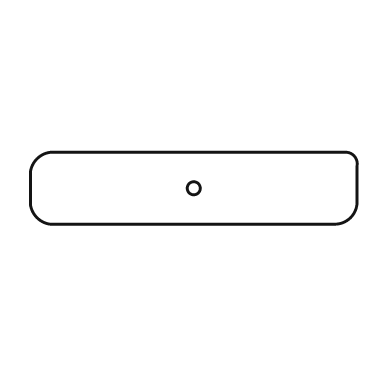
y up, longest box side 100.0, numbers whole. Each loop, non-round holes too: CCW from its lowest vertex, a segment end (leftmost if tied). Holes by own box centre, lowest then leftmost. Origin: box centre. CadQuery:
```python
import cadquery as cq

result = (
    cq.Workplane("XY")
    .moveTo(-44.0, -11.0)
    .lineTo(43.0, -11.0)
    .threePointArc((48.0, -9.0), (50.0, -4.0))
    .lineTo(50.0, 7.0)
    .threePointArc((49.0, 10.0), (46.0, 11.0))
    .lineTo(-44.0, 11.0)
    .threePointArc((-48.0, 9.0), (-50.0, 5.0))
    .lineTo(-50.0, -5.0)
    .threePointArc((-48.0, -9.0), (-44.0, -11.0))
    .close()
    .moveTo(0.0, 0.0)
    .circle(2.0)
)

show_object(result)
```